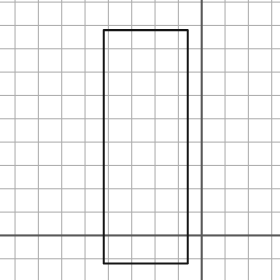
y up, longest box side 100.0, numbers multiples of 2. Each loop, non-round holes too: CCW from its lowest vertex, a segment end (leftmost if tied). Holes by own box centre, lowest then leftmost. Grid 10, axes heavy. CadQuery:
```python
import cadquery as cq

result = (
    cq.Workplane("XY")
    .moveTo(-42.0, -12.0)
    .lineTo(-6.0, -12.0)
    .lineTo(-6.0, 88.0)
    .lineTo(-42.0, 88.0)
    .close()
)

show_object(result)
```